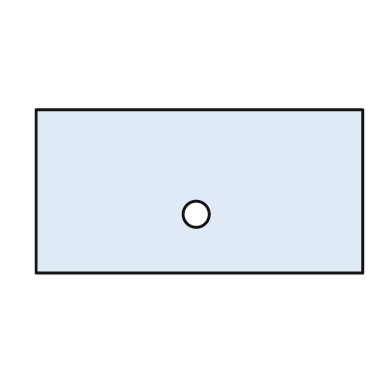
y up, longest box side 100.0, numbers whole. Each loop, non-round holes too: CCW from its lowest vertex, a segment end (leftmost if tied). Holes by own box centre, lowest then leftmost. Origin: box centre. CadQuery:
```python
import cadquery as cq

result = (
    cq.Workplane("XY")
    .moveTo(-50.0, -25.0)
    .lineTo(50.0, -25.0)
    .lineTo(50.0, 25.0)
    .lineTo(-50.0, 25.0)
    .close()
    .moveTo(-1.0, -7.0)
    .circle(4.0)
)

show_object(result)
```